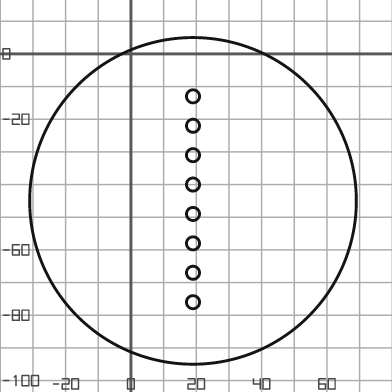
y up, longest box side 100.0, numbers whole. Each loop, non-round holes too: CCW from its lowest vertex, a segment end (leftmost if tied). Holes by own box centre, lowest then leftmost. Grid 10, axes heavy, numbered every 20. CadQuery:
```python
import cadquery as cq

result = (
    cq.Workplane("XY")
    .moveTo(19.0, -45.0)
    .circle(50.0)
    .moveTo(19.0, -76.0)
    .circle(2.0)
    .moveTo(19.0, -67.0)
    .circle(2.0)
    .moveTo(19.0, -58.0)
    .circle(2.0)
    .moveTo(19.0, -49.0)
    .circle(2.0)
    .moveTo(19.0, -40.0)
    .circle(2.0)
    .moveTo(19.0, -31.0)
    .circle(2.0)
    .moveTo(19.0, -22.0)
    .circle(2.0)
    .moveTo(19.0, -13.0)
    .circle(2.0)
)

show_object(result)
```